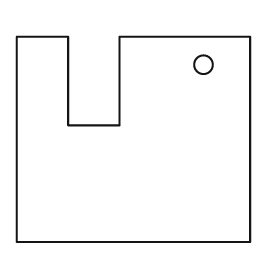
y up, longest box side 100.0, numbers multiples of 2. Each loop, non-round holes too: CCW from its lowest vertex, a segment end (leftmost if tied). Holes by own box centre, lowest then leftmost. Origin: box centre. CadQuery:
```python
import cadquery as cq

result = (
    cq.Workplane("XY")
    .moveTo(-50.0, -44.0)
    .lineTo(50.0, -44.0)
    .lineTo(50.0, 44.0)
    .lineTo(-6.0, 44.0)
    .lineTo(-6.0, 6.0)
    .lineTo(-28.0, 6.0)
    .lineTo(-28.0, 44.0)
    .lineTo(-50.0, 44.0)
    .close()
    .moveTo(30.0, 32.0)
    .circle(4.0)
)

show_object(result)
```